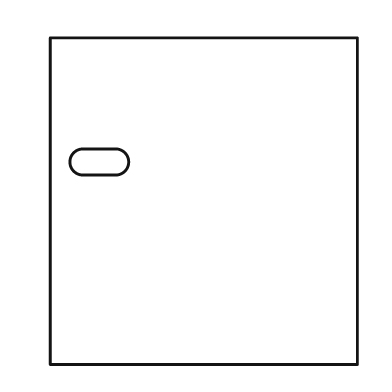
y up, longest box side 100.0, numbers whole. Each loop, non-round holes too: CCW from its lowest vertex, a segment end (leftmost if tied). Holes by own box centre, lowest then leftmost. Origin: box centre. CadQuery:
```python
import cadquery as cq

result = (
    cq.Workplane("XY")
    .moveTo(-47.0, -50.0)
    .lineTo(47.0, -50.0)
    .lineTo(47.0, 50.0)
    .lineTo(-47.0, 50.0)
    .close()
    .moveTo(-37.0, 8.0)
    .lineTo(-27.0, 8.0)
    .threePointArc((-23.0, 12.0), (-27.0, 16.0))
    .lineTo(-37.0, 16.0)
    .threePointArc((-41.0, 12.0), (-37.0, 8.0))
    .close()
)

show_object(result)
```